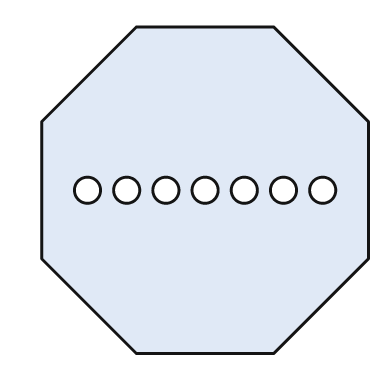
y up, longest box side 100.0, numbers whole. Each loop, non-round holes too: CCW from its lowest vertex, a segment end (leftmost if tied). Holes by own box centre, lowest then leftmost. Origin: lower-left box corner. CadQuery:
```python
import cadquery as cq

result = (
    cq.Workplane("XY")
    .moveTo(29.0, 0.0)
    .lineTo(71.0, 0.0)
    .lineTo(100.0, 29.0)
    .lineTo(100.0, 71.0)
    .lineTo(71.0, 100.0)
    .lineTo(29.0, 100.0)
    .lineTo(0.0, 71.0)
    .lineTo(0.0, 29.0)
    .close()
    .moveTo(14.0, 50.0)
    .circle(4.0)
    .moveTo(26.0, 50.0)
    .circle(4.0)
    .moveTo(38.0, 50.0)
    .circle(4.0)
    .moveTo(50.0, 50.0)
    .circle(4.0)
    .moveTo(62.0, 50.0)
    .circle(4.0)
    .moveTo(74.0, 50.0)
    .circle(4.0)
    .moveTo(86.0, 50.0)
    .circle(4.0)
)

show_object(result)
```